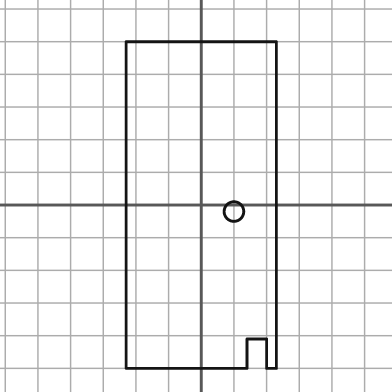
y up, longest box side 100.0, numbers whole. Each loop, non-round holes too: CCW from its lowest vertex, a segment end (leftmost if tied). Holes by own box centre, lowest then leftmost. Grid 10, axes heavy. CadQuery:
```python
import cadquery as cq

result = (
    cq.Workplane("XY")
    .moveTo(-23.0, -50.0)
    .lineTo(14.0, -50.0)
    .lineTo(14.0, -41.0)
    .lineTo(20.0, -41.0)
    .lineTo(20.0, -50.0)
    .lineTo(23.0, -50.0)
    .lineTo(23.0, 50.0)
    .lineTo(-23.0, 50.0)
    .close()
    .moveTo(10.0, -2.0)
    .circle(3.0)
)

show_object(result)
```